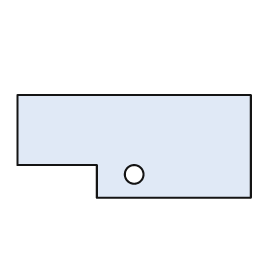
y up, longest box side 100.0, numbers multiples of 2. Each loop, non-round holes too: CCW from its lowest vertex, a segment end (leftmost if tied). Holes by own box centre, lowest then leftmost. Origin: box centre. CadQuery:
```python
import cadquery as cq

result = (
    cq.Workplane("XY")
    .moveTo(-16.0, -22.0)
    .lineTo(50.0, -22.0)
    .lineTo(50.0, 22.0)
    .lineTo(-50.0, 22.0)
    .lineTo(-50.0, -8.0)
    .lineTo(-16.0, -8.0)
    .close()
    .moveTo(0.0, -12.0)
    .circle(4.0)
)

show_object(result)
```